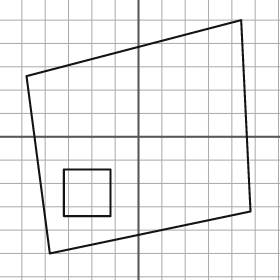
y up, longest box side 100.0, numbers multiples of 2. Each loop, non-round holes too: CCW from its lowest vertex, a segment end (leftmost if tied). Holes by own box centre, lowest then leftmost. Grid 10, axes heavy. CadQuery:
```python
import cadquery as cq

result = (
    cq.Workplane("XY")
    .moveTo(-38.0, -50.0)
    .lineTo(48.0, -32.0)
    .lineTo(44.0, 50.0)
    .lineTo(-48.0, 26.0)
    .close()
    .moveTo(-32.0, -34.0)
    .lineTo(-12.0, -34.0)
    .lineTo(-12.0, -14.0)
    .lineTo(-32.0, -14.0)
    .close()
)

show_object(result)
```